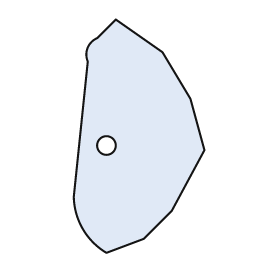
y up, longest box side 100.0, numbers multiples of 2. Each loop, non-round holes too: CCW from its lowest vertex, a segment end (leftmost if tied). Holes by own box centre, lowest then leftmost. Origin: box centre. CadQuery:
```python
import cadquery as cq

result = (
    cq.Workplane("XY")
    .moveTo(-14.0, -50.0)
    .lineTo(2.0, -44.0)
    .lineTo(14.0, -32.0)
    .lineTo(28.0, -6.0)
    .lineTo(22.0, 16.0)
    .lineTo(10.0, 36.0)
    .lineTo(-10.0, 50.0)
    .lineTo(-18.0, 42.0)
    .threePointArc((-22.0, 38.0), (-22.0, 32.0))
    .lineTo(-28.0, -26.0)
    .threePointArc((-24.0, -40.0), (-14.0, -50.0))
    .close()
    .moveTo(-14.0, -4.0)
    .circle(4.0)
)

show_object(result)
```